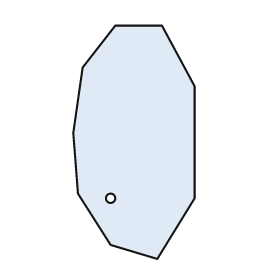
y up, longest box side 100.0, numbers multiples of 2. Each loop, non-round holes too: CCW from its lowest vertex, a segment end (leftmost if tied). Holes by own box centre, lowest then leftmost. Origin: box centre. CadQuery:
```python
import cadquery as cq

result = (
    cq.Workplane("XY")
    .moveTo(10.0, -50.0)
    .lineTo(26.0, -24.0)
    .lineTo(26.0, 24.0)
    .lineTo(12.0, 50.0)
    .lineTo(-8.0, 50.0)
    .lineTo(-22.0, 32.0)
    .lineTo(-26.0, 4.0)
    .lineTo(-24.0, -22.0)
    .lineTo(-10.0, -44.0)
    .close()
    .moveTo(-10.0, -24.0)
    .circle(2.0)
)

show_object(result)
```